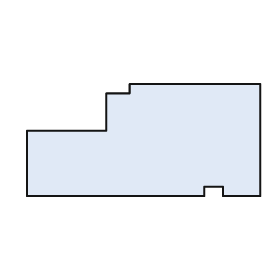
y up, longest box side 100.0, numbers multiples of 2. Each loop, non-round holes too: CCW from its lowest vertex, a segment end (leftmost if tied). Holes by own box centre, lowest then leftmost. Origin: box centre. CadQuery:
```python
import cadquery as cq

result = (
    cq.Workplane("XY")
    .moveTo(-50.0, -24.0)
    .lineTo(26.0, -24.0)
    .lineTo(26.0, -20.0)
    .lineTo(34.0, -20.0)
    .lineTo(34.0, -24.0)
    .lineTo(50.0, -24.0)
    .lineTo(50.0, 24.0)
    .lineTo(-6.0, 24.0)
    .lineTo(-6.0, 20.0)
    .lineTo(-16.0, 20.0)
    .lineTo(-16.0, 4.0)
    .lineTo(-50.0, 4.0)
    .close()
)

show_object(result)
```